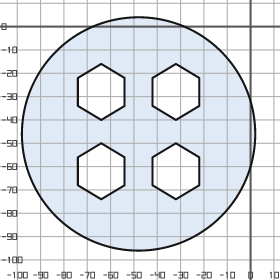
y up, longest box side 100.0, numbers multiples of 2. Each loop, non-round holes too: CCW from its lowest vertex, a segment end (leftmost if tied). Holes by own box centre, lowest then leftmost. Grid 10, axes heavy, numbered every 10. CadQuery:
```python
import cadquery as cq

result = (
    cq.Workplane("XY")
    .moveTo(-48.0, -46.0)
    .circle(50.0)
    .moveTo(-64.0, -74.0)
    .lineTo(-54.0, -68.0)
    .lineTo(-54.0, -56.0)
    .lineTo(-64.0, -50.0)
    .lineTo(-74.0, -56.0)
    .lineTo(-74.0, -68.0)
    .close()
    .moveTo(-32.0, -74.0)
    .lineTo(-22.0, -68.0)
    .lineTo(-22.0, -56.0)
    .lineTo(-32.0, -50.0)
    .lineTo(-42.0, -56.0)
    .lineTo(-42.0, -68.0)
    .close()
    .moveTo(-64.0, -40.0)
    .lineTo(-54.0, -34.0)
    .lineTo(-54.0, -22.0)
    .lineTo(-64.0, -16.0)
    .lineTo(-74.0, -22.0)
    .lineTo(-74.0, -34.0)
    .close()
    .moveTo(-32.0, -40.0)
    .lineTo(-22.0, -34.0)
    .lineTo(-22.0, -22.0)
    .lineTo(-32.0, -16.0)
    .lineTo(-42.0, -22.0)
    .lineTo(-42.0, -34.0)
    .close()
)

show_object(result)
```